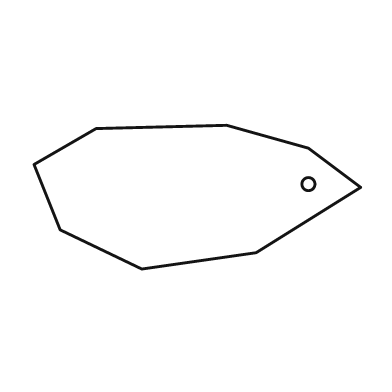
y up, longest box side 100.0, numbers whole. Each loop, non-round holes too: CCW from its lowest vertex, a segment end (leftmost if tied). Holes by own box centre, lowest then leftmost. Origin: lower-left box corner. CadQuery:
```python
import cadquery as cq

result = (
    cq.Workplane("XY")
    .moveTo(33.0, 0.0)
    .lineTo(68.0, 5.0)
    .lineTo(100.0, 25.0)
    .lineTo(84.0, 37.0)
    .lineTo(59.0, 44.0)
    .lineTo(19.0, 43.0)
    .lineTo(0.0, 32.0)
    .lineTo(8.0, 12.0)
    .close()
    .moveTo(84.0, 26.0)
    .circle(2.0)
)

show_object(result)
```